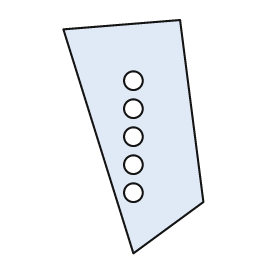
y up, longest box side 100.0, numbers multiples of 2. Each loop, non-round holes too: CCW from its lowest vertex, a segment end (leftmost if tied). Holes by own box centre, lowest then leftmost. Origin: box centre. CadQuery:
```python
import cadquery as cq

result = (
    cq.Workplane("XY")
    .moveTo(0.0, -50.0)
    .lineTo(30.0, -28.0)
    .lineTo(20.0, 50.0)
    .lineTo(-30.0, 46.0)
    .close()
    .moveTo(0.0, -24.0)
    .circle(4.0)
    .moveTo(0.0, -12.0)
    .circle(4.0)
    .moveTo(0.0, 0.0)
    .circle(4.0)
    .moveTo(0.0, 12.0)
    .circle(4.0)
    .moveTo(0.0, 24.0)
    .circle(4.0)
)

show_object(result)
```